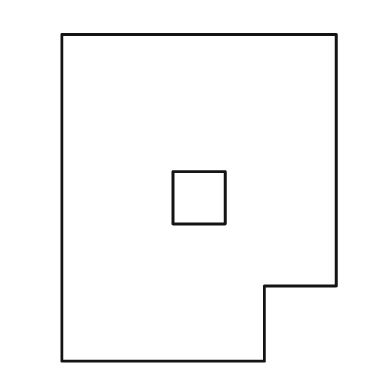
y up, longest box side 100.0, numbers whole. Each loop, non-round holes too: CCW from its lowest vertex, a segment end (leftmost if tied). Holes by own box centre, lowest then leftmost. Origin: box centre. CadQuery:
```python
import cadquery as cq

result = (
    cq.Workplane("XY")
    .moveTo(-42.0, -50.0)
    .lineTo(20.0, -50.0)
    .lineTo(20.0, -27.0)
    .lineTo(42.0, -27.0)
    .lineTo(42.0, 50.0)
    .lineTo(-42.0, 50.0)
    .close()
    .moveTo(-8.0, -8.0)
    .lineTo(8.0, -8.0)
    .lineTo(8.0, 8.0)
    .lineTo(-8.0, 8.0)
    .close()
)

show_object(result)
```